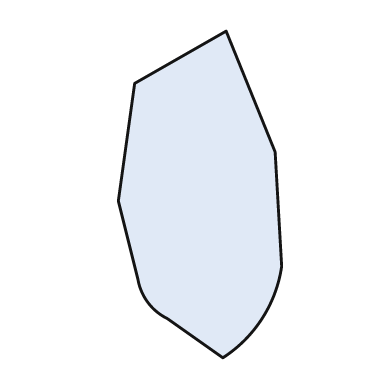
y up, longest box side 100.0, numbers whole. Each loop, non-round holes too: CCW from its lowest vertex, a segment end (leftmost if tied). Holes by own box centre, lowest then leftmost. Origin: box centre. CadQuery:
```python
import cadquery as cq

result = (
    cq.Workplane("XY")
    .moveTo(7.0, -50.0)
    .threePointArc((19.0, -38.0), (25.0, -22.0))
    .lineTo(23.0, 13.0)
    .lineTo(8.0, 50.0)
    .lineTo(-20.0, 34.0)
    .lineTo(-25.0, -2.0)
    .lineTo(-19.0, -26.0)
    .threePointArc((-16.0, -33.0), (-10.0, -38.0))
    .close()
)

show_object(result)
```